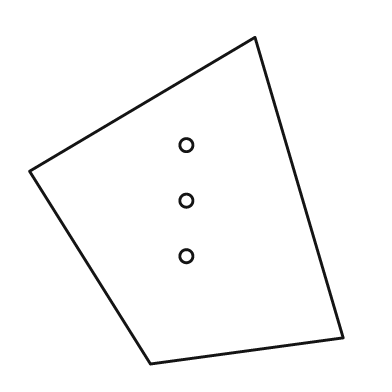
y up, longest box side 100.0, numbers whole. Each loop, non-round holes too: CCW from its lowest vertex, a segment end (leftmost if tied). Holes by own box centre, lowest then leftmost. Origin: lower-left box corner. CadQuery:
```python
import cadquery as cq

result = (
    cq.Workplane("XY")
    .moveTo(37.0, 0.0)
    .lineTo(96.0, 8.0)
    .lineTo(69.0, 100.0)
    .lineTo(0.0, 59.0)
    .close()
    .moveTo(48.0, 33.0)
    .circle(2.0)
    .moveTo(48.0, 50.0)
    .circle(2.0)
    .moveTo(48.0, 67.0)
    .circle(2.0)
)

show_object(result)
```